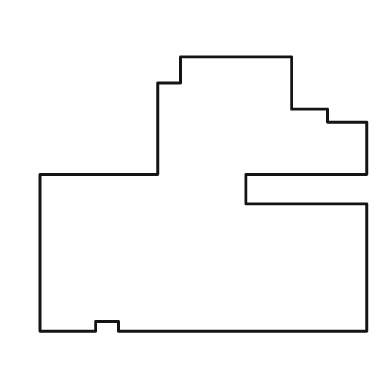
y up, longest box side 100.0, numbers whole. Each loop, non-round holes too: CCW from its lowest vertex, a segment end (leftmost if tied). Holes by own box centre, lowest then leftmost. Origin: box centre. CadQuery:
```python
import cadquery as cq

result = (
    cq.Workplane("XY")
    .moveTo(-50.0, -42.0)
    .lineTo(-33.0, -42.0)
    .lineTo(-33.0, -39.0)
    .lineTo(-26.0, -39.0)
    .lineTo(-26.0, -42.0)
    .lineTo(50.0, -42.0)
    .lineTo(50.0, -3.0)
    .lineTo(13.0, -3.0)
    .lineTo(13.0, 6.0)
    .lineTo(50.0, 6.0)
    .lineTo(50.0, 22.0)
    .lineTo(38.0, 22.0)
    .lineTo(38.0, 26.0)
    .lineTo(27.0, 26.0)
    .lineTo(27.0, 42.0)
    .lineTo(-7.0, 42.0)
    .lineTo(-7.0, 34.0)
    .lineTo(-14.0, 34.0)
    .lineTo(-14.0, 6.0)
    .lineTo(-50.0, 6.0)
    .close()
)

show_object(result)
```